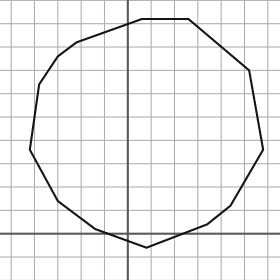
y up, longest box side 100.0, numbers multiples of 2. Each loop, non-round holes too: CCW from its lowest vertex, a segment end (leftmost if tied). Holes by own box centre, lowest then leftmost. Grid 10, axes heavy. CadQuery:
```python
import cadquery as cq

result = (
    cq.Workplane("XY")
    .moveTo(8.0, -6.0)
    .lineTo(34.0, 4.0)
    .lineTo(44.0, 12.0)
    .lineTo(58.0, 36.0)
    .lineTo(52.0, 70.0)
    .lineTo(26.0, 92.0)
    .lineTo(6.0, 92.0)
    .lineTo(-22.0, 82.0)
    .lineTo(-30.0, 76.0)
    .lineTo(-38.0, 64.0)
    .lineTo(-42.0, 36.0)
    .lineTo(-30.0, 14.0)
    .lineTo(-14.0, 2.0)
    .close()
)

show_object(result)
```